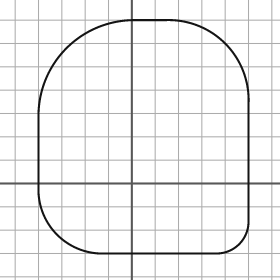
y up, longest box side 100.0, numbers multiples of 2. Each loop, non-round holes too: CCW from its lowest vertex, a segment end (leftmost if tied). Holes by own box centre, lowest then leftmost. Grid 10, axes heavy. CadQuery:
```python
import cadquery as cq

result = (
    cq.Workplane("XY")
    .moveTo(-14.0, -30.0)
    .lineTo(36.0, -30.0)
    .threePointArc((46.0, -26.0), (50.0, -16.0))
    .lineTo(50.0, 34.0)
    .threePointArc((40.0, 60.0), (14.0, 70.0))
    .lineTo(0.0, 70.0)
    .threePointArc((-28.0, 58.0), (-40.0, 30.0))
    .lineTo(-40.0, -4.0)
    .threePointArc((-32.0, -22.0), (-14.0, -30.0))
    .close()
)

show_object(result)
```